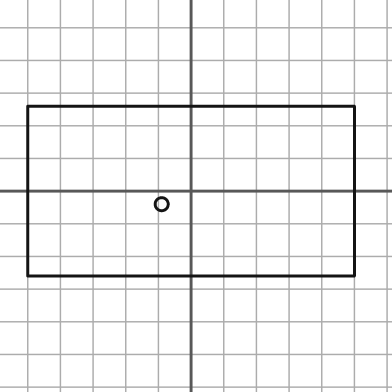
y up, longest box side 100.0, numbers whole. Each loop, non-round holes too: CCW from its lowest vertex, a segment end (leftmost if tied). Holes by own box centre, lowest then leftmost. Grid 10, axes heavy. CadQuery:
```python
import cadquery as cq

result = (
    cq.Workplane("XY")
    .moveTo(-50.0, -26.0)
    .lineTo(50.0, -26.0)
    .lineTo(50.0, 26.0)
    .lineTo(-50.0, 26.0)
    .close()
    .moveTo(-9.0, -4.0)
    .circle(2.0)
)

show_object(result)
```